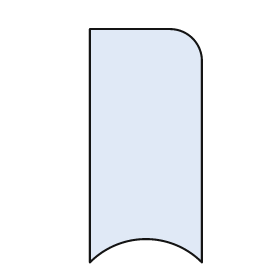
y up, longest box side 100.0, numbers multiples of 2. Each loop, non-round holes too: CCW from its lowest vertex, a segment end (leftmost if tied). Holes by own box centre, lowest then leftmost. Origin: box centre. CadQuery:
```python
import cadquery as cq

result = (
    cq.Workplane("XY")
    .moveTo(-24.0, -50.0)
    .threePointArc((0.0, -40.0), (24.0, -50.0))
    .lineTo(24.0, 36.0)
    .threePointArc((20.0, 46.0), (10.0, 50.0))
    .lineTo(-24.0, 50.0)
    .close()
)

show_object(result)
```